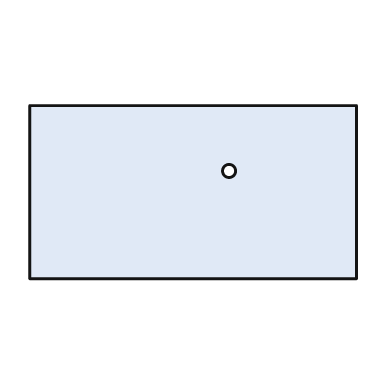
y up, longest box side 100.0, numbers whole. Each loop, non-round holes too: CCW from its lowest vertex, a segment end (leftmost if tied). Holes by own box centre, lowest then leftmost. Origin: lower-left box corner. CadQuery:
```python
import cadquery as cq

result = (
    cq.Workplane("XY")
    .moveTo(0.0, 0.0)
    .lineTo(100.0, 0.0)
    .lineTo(100.0, 53.0)
    .lineTo(0.0, 53.0)
    .close()
    .moveTo(61.0, 33.0)
    .circle(2.0)
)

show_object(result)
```